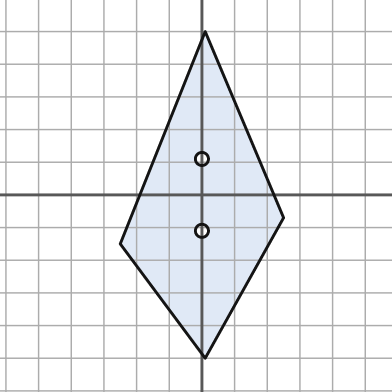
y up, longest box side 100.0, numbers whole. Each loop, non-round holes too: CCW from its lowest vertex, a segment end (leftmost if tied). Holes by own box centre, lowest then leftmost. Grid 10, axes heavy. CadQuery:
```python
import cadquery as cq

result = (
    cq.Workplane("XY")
    .moveTo(1.0, -50.0)
    .lineTo(25.0, -7.0)
    .lineTo(1.0, 50.0)
    .lineTo(-25.0, -15.0)
    .close()
    .moveTo(0.0, -11.0)
    .circle(2.0)
    .moveTo(0.0, 11.0)
    .circle(2.0)
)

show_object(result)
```